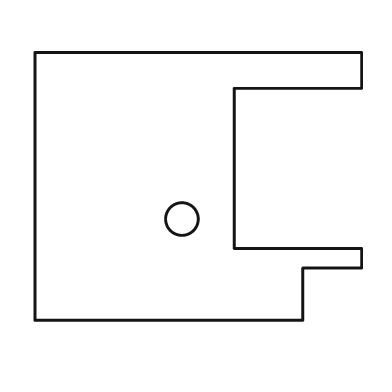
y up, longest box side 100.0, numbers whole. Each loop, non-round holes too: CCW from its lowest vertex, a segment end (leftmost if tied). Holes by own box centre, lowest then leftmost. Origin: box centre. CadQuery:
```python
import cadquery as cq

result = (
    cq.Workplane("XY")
    .moveTo(-50.0, -41.0)
    .lineTo(32.0, -41.0)
    .lineTo(32.0, -25.0)
    .lineTo(50.0, -25.0)
    .lineTo(50.0, -19.0)
    .lineTo(11.0, -19.0)
    .lineTo(11.0, 30.0)
    .lineTo(50.0, 30.0)
    .lineTo(50.0, 41.0)
    .lineTo(-50.0, 41.0)
    .close()
    .moveTo(-5.0, -10.0)
    .circle(5.0)
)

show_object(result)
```